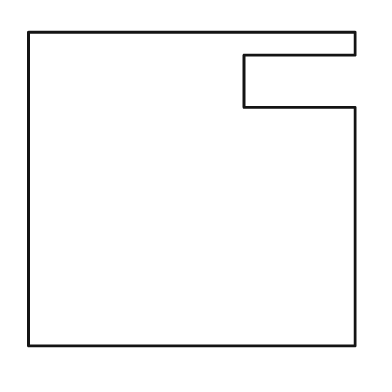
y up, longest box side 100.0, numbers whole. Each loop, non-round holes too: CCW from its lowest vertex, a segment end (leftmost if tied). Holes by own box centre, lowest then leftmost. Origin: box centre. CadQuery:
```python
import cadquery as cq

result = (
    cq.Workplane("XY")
    .moveTo(-50.0, -48.0)
    .lineTo(50.0, -48.0)
    .lineTo(50.0, 25.0)
    .lineTo(16.0, 25.0)
    .lineTo(16.0, 41.0)
    .lineTo(50.0, 41.0)
    .lineTo(50.0, 48.0)
    .lineTo(-50.0, 48.0)
    .close()
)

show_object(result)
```